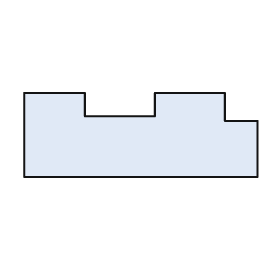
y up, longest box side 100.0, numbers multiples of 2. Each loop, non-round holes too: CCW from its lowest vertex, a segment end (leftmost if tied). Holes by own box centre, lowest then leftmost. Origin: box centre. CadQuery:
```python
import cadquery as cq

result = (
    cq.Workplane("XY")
    .moveTo(-50.0, -18.0)
    .lineTo(50.0, -18.0)
    .lineTo(50.0, 6.0)
    .lineTo(36.0, 6.0)
    .lineTo(36.0, 18.0)
    .lineTo(6.0, 18.0)
    .lineTo(6.0, 8.0)
    .lineTo(-24.0, 8.0)
    .lineTo(-24.0, 18.0)
    .lineTo(-50.0, 18.0)
    .close()
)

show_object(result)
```